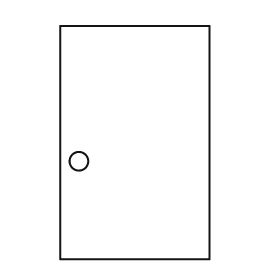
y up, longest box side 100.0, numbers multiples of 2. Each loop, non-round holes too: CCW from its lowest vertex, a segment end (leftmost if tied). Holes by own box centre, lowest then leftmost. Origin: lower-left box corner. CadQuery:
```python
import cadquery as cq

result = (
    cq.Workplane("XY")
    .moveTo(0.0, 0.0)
    .lineTo(64.0, 0.0)
    .lineTo(64.0, 100.0)
    .lineTo(0.0, 100.0)
    .close()
    .moveTo(8.0, 42.0)
    .circle(4.0)
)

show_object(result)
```